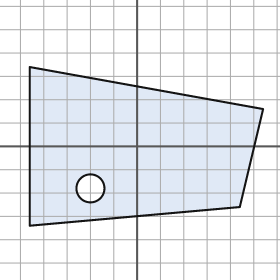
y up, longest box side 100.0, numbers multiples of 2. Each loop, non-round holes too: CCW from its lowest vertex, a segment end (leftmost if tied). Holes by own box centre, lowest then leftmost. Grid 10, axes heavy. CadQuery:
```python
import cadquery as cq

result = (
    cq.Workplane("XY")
    .moveTo(-46.0, -34.0)
    .lineTo(44.0, -26.0)
    .lineTo(54.0, 16.0)
    .lineTo(-46.0, 34.0)
    .close()
    .moveTo(-20.0, -18.0)
    .circle(6.0)
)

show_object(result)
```